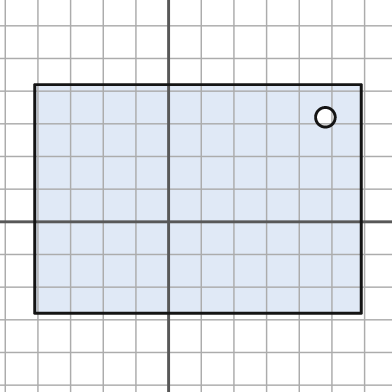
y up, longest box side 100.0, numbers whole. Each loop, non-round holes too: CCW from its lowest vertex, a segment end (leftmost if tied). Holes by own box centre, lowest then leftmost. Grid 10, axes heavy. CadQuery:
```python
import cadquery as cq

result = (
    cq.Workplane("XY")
    .moveTo(-41.0, -28.0)
    .lineTo(59.0, -28.0)
    .lineTo(59.0, 42.0)
    .lineTo(-41.0, 42.0)
    .close()
    .moveTo(48.0, 32.0)
    .circle(3.0)
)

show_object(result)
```